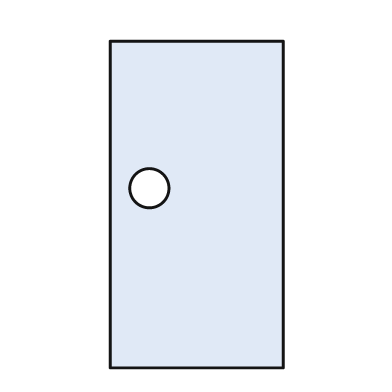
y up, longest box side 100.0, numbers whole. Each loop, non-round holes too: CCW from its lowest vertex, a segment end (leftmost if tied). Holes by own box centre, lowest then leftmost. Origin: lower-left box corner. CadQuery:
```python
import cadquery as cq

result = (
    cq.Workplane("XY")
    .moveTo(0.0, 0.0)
    .lineTo(53.0, 0.0)
    .lineTo(53.0, 100.0)
    .lineTo(0.0, 100.0)
    .close()
    .moveTo(12.0, 55.0)
    .circle(6.0)
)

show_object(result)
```